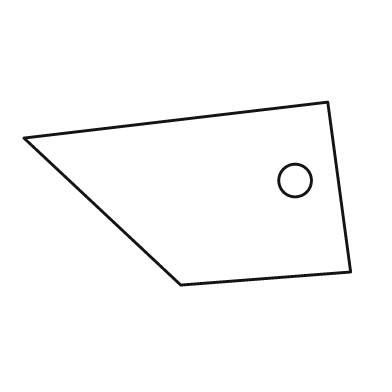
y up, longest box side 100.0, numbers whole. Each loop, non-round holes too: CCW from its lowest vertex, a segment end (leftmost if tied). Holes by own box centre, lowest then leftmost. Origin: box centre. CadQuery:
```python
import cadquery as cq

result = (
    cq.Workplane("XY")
    .moveTo(-2.0, -28.0)
    .lineTo(50.0, -24.0)
    .lineTo(43.0, 28.0)
    .lineTo(-50.0, 17.0)
    .close()
    .moveTo(33.0, 4.0)
    .circle(5.0)
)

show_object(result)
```